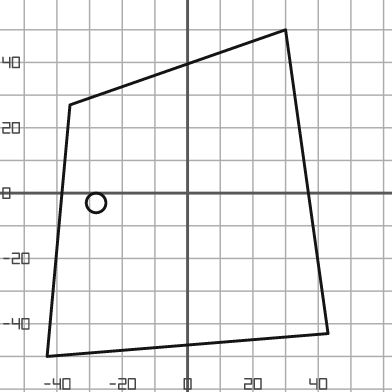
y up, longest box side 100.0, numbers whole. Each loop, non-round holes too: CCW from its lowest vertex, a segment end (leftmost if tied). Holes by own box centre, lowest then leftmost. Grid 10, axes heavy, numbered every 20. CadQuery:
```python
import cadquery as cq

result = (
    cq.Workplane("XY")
    .moveTo(-43.0, -50.0)
    .lineTo(43.0, -43.0)
    .lineTo(30.0, 50.0)
    .lineTo(-36.0, 27.0)
    .close()
    .moveTo(-28.0, -3.0)
    .circle(3.0)
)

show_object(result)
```